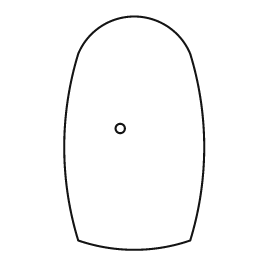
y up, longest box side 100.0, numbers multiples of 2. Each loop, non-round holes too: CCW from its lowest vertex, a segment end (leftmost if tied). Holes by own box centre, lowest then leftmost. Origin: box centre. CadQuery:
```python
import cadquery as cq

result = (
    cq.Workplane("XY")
    .moveTo(-24.0, -46.0)
    .threePointArc((0.0, -50.0), (24.0, -46.0))
    .threePointArc((30.0, -6.0), (24.0, 34.0))
    .threePointArc((0.0, 50.0), (-24.0, 34.0))
    .threePointArc((-30.0, -6.0), (-24.0, -46.0))
    .close()
    .moveTo(-6.0, 2.0)
    .circle(2.0)
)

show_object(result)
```